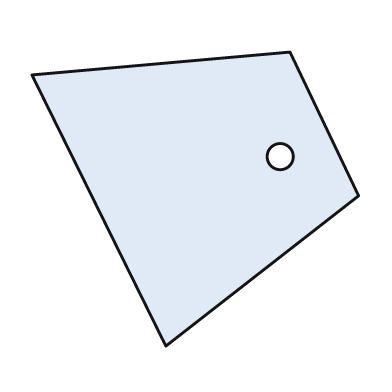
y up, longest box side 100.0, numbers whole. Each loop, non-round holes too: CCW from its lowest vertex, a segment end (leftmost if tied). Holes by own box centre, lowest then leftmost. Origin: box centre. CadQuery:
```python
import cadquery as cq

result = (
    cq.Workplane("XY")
    .moveTo(-9.0, -45.0)
    .lineTo(50.0, 1.0)
    .lineTo(29.0, 45.0)
    .lineTo(-50.0, 38.0)
    .close()
    .moveTo(26.0, 13.0)
    .circle(4.0)
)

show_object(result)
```